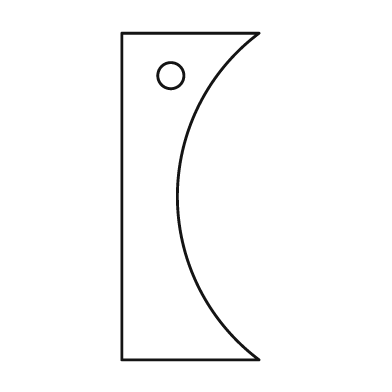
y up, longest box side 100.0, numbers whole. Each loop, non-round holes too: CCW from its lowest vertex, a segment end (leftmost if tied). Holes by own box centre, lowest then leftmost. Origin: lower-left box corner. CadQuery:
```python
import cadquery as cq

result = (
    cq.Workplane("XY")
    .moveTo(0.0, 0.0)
    .lineTo(42.0, 0.0)
    .threePointArc((17.0, 50.0), (42.0, 100.0))
    .lineTo(0.0, 100.0)
    .close()
    .moveTo(15.0, 87.0)
    .circle(4.0)
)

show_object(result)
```